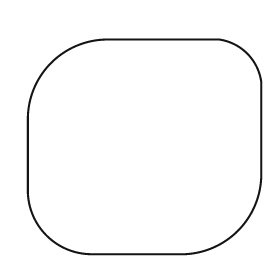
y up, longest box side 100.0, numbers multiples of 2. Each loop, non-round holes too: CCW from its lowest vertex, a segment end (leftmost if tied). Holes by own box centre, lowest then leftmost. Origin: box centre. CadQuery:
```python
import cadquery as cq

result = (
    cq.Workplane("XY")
    .moveTo(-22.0, -46.0)
    .lineTo(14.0, -46.0)
    .threePointArc((40.0, -36.0), (50.0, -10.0))
    .lineTo(50.0, 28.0)
    .threePointArc((44.0, 40.0), (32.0, 46.0))
    .lineTo(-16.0, 46.0)
    .threePointArc((-40.0, 36.0), (-50.0, 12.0))
    .lineTo(-50.0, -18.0)
    .threePointArc((-42.0, -38.0), (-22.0, -46.0))
    .close()
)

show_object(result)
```